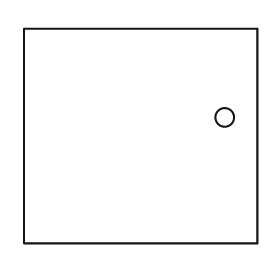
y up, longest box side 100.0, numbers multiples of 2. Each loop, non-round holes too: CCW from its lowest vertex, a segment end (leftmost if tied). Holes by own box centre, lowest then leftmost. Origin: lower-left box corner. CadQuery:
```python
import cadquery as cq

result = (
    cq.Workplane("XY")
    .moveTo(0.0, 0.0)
    .lineTo(100.0, 0.0)
    .lineTo(100.0, 92.0)
    .lineTo(0.0, 92.0)
    .close()
    .moveTo(86.0, 54.0)
    .circle(4.0)
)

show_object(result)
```